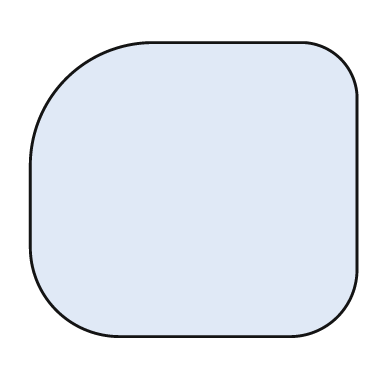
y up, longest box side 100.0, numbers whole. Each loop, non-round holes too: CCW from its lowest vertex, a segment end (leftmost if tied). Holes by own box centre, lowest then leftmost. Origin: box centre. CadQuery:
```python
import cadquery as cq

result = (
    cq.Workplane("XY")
    .moveTo(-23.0, -45.0)
    .lineTo(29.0, -45.0)
    .threePointArc((44.0, -39.0), (50.0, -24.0))
    .lineTo(50.0, 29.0)
    .threePointArc((45.0, 40.0), (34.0, 45.0))
    .lineTo(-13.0, 45.0)
    .threePointArc((-39.0, 34.0), (-50.0, 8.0))
    .lineTo(-50.0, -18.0)
    .threePointArc((-42.0, -37.0), (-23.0, -45.0))
    .close()
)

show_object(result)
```